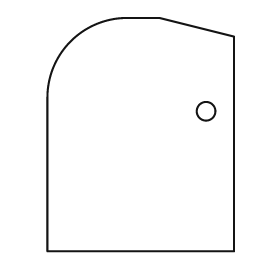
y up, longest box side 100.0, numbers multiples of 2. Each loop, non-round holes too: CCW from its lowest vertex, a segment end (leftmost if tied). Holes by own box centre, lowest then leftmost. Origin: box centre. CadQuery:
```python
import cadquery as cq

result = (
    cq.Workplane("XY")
    .moveTo(-40.0, -50.0)
    .lineTo(40.0, -50.0)
    .lineTo(40.0, 42.0)
    .lineTo(8.0, 50.0)
    .lineTo(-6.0, 50.0)
    .threePointArc((-30.0, 40.0), (-40.0, 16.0))
    .close()
    .moveTo(28.0, 10.0)
    .circle(4.0)
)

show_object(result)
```